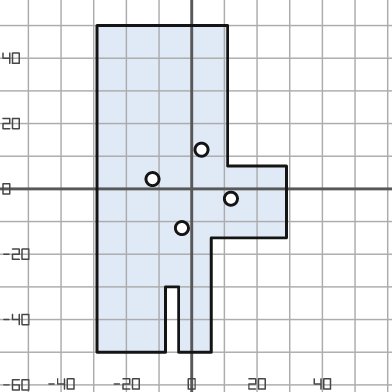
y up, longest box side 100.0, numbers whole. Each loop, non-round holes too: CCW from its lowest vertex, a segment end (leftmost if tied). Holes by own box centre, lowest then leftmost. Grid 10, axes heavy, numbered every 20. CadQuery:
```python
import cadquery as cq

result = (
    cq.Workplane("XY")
    .moveTo(-29.0, -50.0)
    .lineTo(-8.0, -50.0)
    .lineTo(-8.0, -30.0)
    .lineTo(-4.0, -30.0)
    .lineTo(-4.0, -50.0)
    .lineTo(6.0, -50.0)
    .lineTo(6.0, -15.0)
    .lineTo(29.0, -15.0)
    .lineTo(29.0, 7.0)
    .lineTo(11.0, 7.0)
    .lineTo(11.0, 50.0)
    .lineTo(-29.0, 50.0)
    .close()
    .moveTo(-3.0, -12.0)
    .circle(2.0)
    .moveTo(12.0, -3.0)
    .circle(2.0)
    .moveTo(-12.0, 3.0)
    .circle(2.0)
    .moveTo(3.0, 12.0)
    .circle(2.0)
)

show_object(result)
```